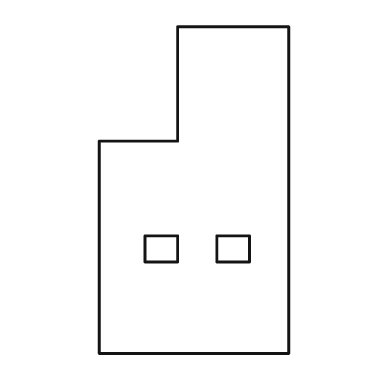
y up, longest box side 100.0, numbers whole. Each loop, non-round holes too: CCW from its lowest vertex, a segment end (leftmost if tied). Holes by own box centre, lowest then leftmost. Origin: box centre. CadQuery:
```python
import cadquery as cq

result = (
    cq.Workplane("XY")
    .moveTo(-29.0, -50.0)
    .lineTo(29.0, -50.0)
    .lineTo(29.0, 50.0)
    .lineTo(-5.0, 50.0)
    .lineTo(-5.0, 15.0)
    .lineTo(-29.0, 15.0)
    .close()
    .moveTo(-15.0, -22.0)
    .lineTo(-5.0, -22.0)
    .lineTo(-5.0, -14.0)
    .lineTo(-15.0, -14.0)
    .close()
    .moveTo(7.0, -22.0)
    .lineTo(17.0, -22.0)
    .lineTo(17.0, -14.0)
    .lineTo(7.0, -14.0)
    .close()
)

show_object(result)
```